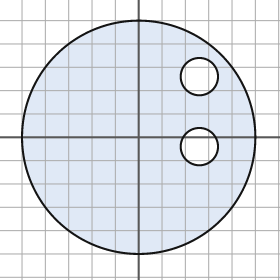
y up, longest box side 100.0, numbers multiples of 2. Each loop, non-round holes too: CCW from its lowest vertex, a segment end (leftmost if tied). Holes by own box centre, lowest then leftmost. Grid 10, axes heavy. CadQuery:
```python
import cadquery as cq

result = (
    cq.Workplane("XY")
    .moveTo(0.0, 0.0)
    .circle(50.0)
    .moveTo(26.0, -4.0)
    .circle(8.0)
    .moveTo(26.0, 26.0)
    .circle(8.0)
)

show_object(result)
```